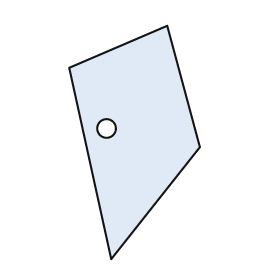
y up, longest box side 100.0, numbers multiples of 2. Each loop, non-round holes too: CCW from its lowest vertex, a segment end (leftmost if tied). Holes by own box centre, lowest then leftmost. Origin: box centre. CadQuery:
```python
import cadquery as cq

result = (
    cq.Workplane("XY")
    .moveTo(-10.0, -50.0)
    .lineTo(28.0, -2.0)
    .lineTo(14.0, 50.0)
    .lineTo(-28.0, 32.0)
    .close()
    .moveTo(-12.0, 6.0)
    .circle(4.0)
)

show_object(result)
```